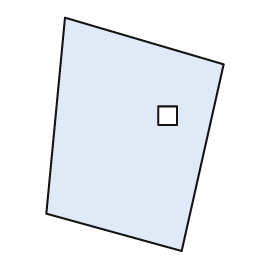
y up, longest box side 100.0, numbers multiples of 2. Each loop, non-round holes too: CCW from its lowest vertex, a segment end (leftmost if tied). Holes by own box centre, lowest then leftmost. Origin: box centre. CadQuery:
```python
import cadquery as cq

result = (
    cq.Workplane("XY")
    .moveTo(20.0, -50.0)
    .lineTo(38.0, 30.0)
    .lineTo(-30.0, 50.0)
    .lineTo(-38.0, -34.0)
    .close()
    .moveTo(10.0, 4.0)
    .lineTo(18.0, 4.0)
    .lineTo(18.0, 12.0)
    .lineTo(10.0, 12.0)
    .close()
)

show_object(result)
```